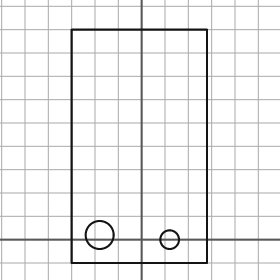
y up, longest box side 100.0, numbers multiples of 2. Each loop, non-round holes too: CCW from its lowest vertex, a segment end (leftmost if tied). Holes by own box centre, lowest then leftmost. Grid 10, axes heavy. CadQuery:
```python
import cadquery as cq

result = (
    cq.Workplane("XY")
    .moveTo(-30.0, -10.0)
    .lineTo(28.0, -10.0)
    .lineTo(28.0, 90.0)
    .lineTo(-30.0, 90.0)
    .close()
    .moveTo(12.0, 0.0)
    .circle(4.0)
    .moveTo(-18.0, 2.0)
    .circle(6.0)
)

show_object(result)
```